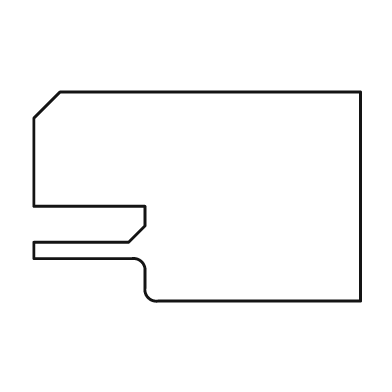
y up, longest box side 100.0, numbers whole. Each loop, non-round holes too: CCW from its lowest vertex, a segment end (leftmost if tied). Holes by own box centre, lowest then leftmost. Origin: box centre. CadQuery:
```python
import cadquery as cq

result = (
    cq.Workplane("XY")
    .moveTo(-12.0, -32.0)
    .lineTo(50.0, -32.0)
    .lineTo(50.0, 32.0)
    .lineTo(-42.0, 32.0)
    .lineTo(-50.0, 24.0)
    .lineTo(-50.0, -3.0)
    .lineTo(-16.0, -3.0)
    .lineTo(-16.0, -9.0)
    .lineTo(-21.0, -14.0)
    .lineTo(-50.0, -14.0)
    .lineTo(-50.0, -19.0)
    .lineTo(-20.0, -19.0)
    .threePointArc((-17.0, -20.0), (-16.0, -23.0))
    .lineTo(-16.0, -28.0)
    .threePointArc((-15.0, -31.0), (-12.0, -32.0))
    .close()
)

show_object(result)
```